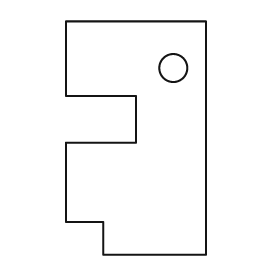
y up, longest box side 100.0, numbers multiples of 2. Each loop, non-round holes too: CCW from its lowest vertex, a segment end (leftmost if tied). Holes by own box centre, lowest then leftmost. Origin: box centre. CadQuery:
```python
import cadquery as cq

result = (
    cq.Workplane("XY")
    .moveTo(-14.0, -50.0)
    .lineTo(30.0, -50.0)
    .lineTo(30.0, 50.0)
    .lineTo(-30.0, 50.0)
    .lineTo(-30.0, 18.0)
    .lineTo(0.0, 18.0)
    .lineTo(0.0, -2.0)
    .lineTo(-30.0, -2.0)
    .lineTo(-30.0, -36.0)
    .lineTo(-14.0, -36.0)
    .close()
    .moveTo(16.0, 30.0)
    .circle(6.0)
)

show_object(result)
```